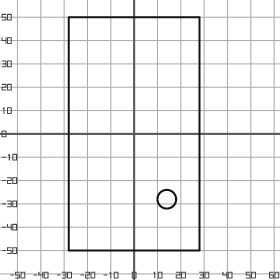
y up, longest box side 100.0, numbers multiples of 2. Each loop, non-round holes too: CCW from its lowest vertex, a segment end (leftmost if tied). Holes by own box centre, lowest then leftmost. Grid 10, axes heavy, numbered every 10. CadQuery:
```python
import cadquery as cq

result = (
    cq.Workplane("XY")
    .moveTo(-28.0, -50.0)
    .lineTo(28.0, -50.0)
    .lineTo(28.0, 50.0)
    .lineTo(-28.0, 50.0)
    .close()
    .moveTo(14.0, -28.0)
    .circle(4.0)
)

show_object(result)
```